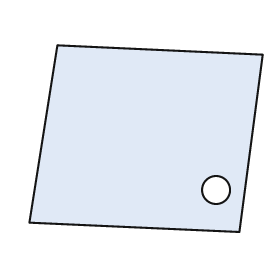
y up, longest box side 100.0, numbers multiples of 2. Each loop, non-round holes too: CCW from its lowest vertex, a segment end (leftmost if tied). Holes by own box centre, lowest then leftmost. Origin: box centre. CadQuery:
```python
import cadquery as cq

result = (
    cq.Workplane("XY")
    .moveTo(40.0, -40.0)
    .lineTo(50.0, 36.0)
    .lineTo(-38.0, 40.0)
    .lineTo(-50.0, -36.0)
    .close()
    .moveTo(30.0, -22.0)
    .circle(6.0)
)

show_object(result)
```